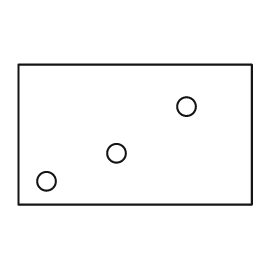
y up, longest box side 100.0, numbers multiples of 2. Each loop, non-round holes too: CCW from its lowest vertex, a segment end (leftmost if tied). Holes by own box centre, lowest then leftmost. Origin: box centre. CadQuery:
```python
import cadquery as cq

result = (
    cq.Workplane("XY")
    .moveTo(-50.0, -30.0)
    .lineTo(50.0, -30.0)
    .lineTo(50.0, 30.0)
    .lineTo(-50.0, 30.0)
    .close()
    .moveTo(-38.0, -20.0)
    .circle(4.0)
    .moveTo(-8.0, -8.0)
    .circle(4.0)
    .moveTo(22.0, 12.0)
    .circle(4.0)
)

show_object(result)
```